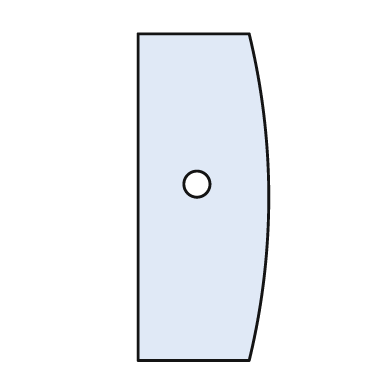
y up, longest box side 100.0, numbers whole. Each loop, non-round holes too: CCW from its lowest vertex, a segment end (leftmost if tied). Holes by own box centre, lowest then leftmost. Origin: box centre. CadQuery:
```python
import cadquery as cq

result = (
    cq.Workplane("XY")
    .moveTo(-20.0, -50.0)
    .lineTo(14.0, -50.0)
    .threePointArc((20.0, 0.0), (14.0, 50.0))
    .lineTo(-20.0, 50.0)
    .close()
    .moveTo(-2.0, 4.0)
    .circle(4.0)
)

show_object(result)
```